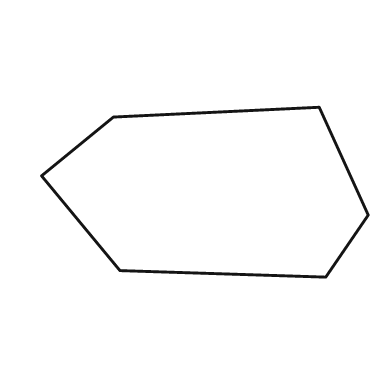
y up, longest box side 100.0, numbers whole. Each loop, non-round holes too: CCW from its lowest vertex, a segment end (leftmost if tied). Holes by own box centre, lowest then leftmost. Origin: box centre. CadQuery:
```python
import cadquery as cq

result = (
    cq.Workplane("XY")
    .moveTo(37.0, -26.0)
    .lineTo(50.0, -7.0)
    .lineTo(35.0, 26.0)
    .lineTo(-28.0, 23.0)
    .lineTo(-50.0, 5.0)
    .lineTo(-26.0, -24.0)
    .close()
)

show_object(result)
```